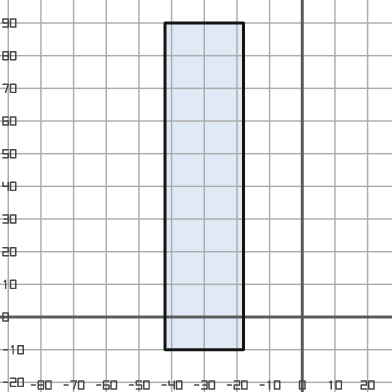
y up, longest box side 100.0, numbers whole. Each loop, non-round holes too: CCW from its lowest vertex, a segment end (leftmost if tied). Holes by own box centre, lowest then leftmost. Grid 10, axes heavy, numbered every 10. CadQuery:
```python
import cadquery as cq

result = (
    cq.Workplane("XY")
    .moveTo(-42.0, -10.0)
    .lineTo(-18.0, -10.0)
    .lineTo(-18.0, 90.0)
    .lineTo(-42.0, 90.0)
    .close()
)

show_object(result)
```